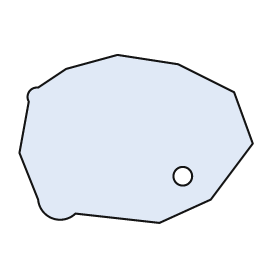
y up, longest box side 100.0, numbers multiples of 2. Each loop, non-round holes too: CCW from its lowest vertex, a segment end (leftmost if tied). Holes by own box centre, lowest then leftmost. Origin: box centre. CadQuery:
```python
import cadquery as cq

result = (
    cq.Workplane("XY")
    .moveTo(10.0, -36.0)
    .lineTo(32.0, -26.0)
    .lineTo(50.0, -2.0)
    .lineTo(42.0, 20.0)
    .lineTo(18.0, 32.0)
    .lineTo(-8.0, 36.0)
    .lineTo(-30.0, 30.0)
    .lineTo(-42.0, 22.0)
    .threePointArc((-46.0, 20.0), (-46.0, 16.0))
    .lineTo(-50.0, -6.0)
    .lineTo(-42.0, -26.0)
    .threePointArc((-36.0, -34.0), (-26.0, -32.0))
    .close()
    .moveTo(20.0, -16.0)
    .circle(4.0)
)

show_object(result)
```